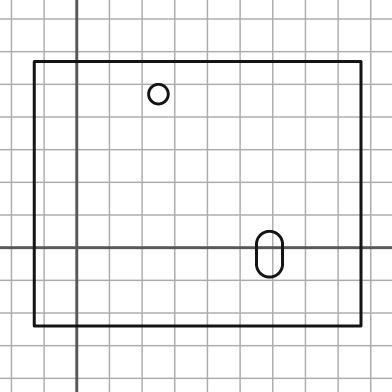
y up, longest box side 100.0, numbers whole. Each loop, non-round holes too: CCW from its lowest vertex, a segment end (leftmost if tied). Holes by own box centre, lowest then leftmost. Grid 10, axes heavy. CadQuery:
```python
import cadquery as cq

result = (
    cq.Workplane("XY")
    .moveTo(-13.0, -24.0)
    .lineTo(87.0, -24.0)
    .lineTo(87.0, 57.0)
    .lineTo(-13.0, 57.0)
    .close()
    .moveTo(55.0, -5.0)
    .threePointArc((59.0, -9.0), (63.0, -5.0))
    .lineTo(63.0, 1.0)
    .threePointArc((59.0, 5.0), (55.0, 1.0))
    .close()
    .moveTo(25.0, 47.0)
    .circle(3.0)
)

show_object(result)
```